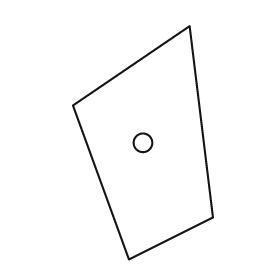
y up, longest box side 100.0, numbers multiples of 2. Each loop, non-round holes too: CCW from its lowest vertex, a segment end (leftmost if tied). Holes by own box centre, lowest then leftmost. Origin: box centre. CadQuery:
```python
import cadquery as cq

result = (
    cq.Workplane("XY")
    .moveTo(-6.0, -50.0)
    .lineTo(30.0, -32.0)
    .lineTo(20.0, 50.0)
    .lineTo(-30.0, 16.0)
    .close()
    .moveTo(0.0, 0.0)
    .circle(4.0)
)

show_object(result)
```